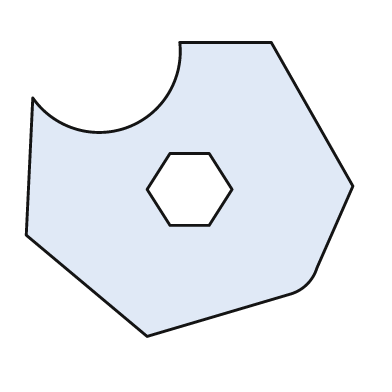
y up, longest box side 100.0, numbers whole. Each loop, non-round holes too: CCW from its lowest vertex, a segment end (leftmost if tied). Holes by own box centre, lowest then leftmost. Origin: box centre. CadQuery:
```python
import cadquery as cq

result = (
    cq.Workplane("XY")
    .moveTo(-13.0, -45.0)
    .lineTo(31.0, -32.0)
    .threePointArc((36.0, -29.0), (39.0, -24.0))
    .lineTo(50.0, 1.0)
    .lineTo(25.0, 45.0)
    .lineTo(-3.0, 45.0)
    .threePointArc((-19.0, 19.0), (-48.0, 28.0))
    .lineTo(-50.0, -14.0)
    .close()
    .moveTo(-6.0, -11.0)
    .lineTo(6.0, -11.0)
    .lineTo(13.0, 0.0)
    .lineTo(6.0, 11.0)
    .lineTo(-6.0, 11.0)
    .lineTo(-13.0, 0.0)
    .close()
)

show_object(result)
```